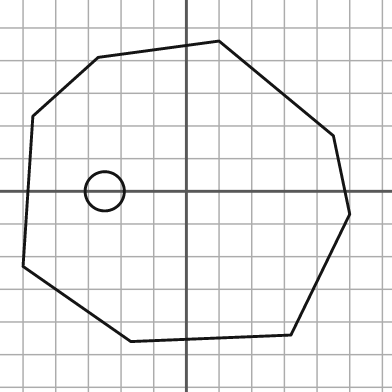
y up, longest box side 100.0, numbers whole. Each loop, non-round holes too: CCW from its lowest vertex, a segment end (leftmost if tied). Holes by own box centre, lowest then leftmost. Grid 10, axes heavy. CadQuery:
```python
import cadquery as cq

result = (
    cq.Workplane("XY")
    .moveTo(-17.0, -46.0)
    .lineTo(32.0, -44.0)
    .lineTo(50.0, -7.0)
    .lineTo(45.0, 17.0)
    .lineTo(10.0, 46.0)
    .lineTo(-27.0, 41.0)
    .lineTo(-47.0, 23.0)
    .lineTo(-50.0, -23.0)
    .close()
    .moveTo(-25.0, 0.0)
    .circle(6.0)
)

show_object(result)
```